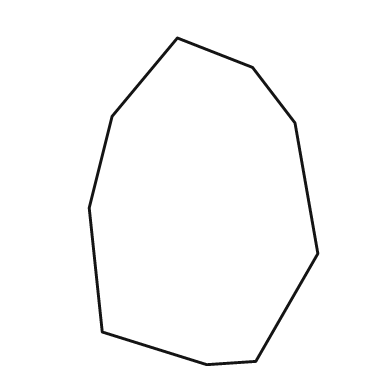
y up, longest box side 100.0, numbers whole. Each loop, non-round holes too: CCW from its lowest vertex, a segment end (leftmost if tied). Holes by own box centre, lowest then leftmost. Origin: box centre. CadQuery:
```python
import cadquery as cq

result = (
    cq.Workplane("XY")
    .moveTo(1.0, -50.0)
    .lineTo(16.0, -49.0)
    .lineTo(35.0, -16.0)
    .lineTo(28.0, 24.0)
    .lineTo(15.0, 41.0)
    .lineTo(-8.0, 50.0)
    .lineTo(-28.0, 26.0)
    .lineTo(-35.0, -2.0)
    .lineTo(-31.0, -40.0)
    .close()
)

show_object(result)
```